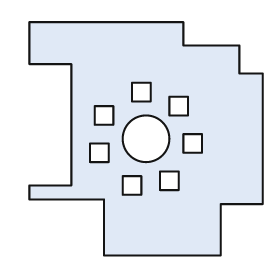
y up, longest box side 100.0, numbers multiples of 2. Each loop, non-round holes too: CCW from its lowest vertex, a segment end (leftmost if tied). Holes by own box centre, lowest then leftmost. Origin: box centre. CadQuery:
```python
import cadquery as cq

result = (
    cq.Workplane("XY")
    .moveTo(-18.0, -50.0)
    .lineTo(32.0, -50.0)
    .lineTo(32.0, -28.0)
    .lineTo(50.0, -28.0)
    .lineTo(50.0, 28.0)
    .lineTo(40.0, 28.0)
    .lineTo(40.0, 40.0)
    .lineTo(16.0, 40.0)
    .lineTo(16.0, 50.0)
    .lineTo(-50.0, 50.0)
    .lineTo(-50.0, 32.0)
    .lineTo(-32.0, 32.0)
    .lineTo(-32.0, -20.0)
    .lineTo(-50.0, -20.0)
    .lineTo(-50.0, -26.0)
    .lineTo(-18.0, -26.0)
    .close()
    .moveTo(-10.0, -24.0)
    .lineTo(-2.0, -24.0)
    .lineTo(-2.0, -16.0)
    .lineTo(-10.0, -16.0)
    .close()
    .moveTo(6.0, -22.0)
    .lineTo(14.0, -22.0)
    .lineTo(14.0, -14.0)
    .lineTo(6.0, -14.0)
    .close()
    .moveTo(-24.0, -10.0)
    .lineTo(-16.0, -10.0)
    .lineTo(-16.0, -2.0)
    .lineTo(-24.0, -2.0)
    .close()
    .moveTo(16.0, -6.0)
    .lineTo(24.0, -6.0)
    .lineTo(24.0, 2.0)
    .lineTo(16.0, 2.0)
    .close()
    .moveTo(0.0, 0.0)
    .circle(10.0)
    .moveTo(-22.0, 6.0)
    .lineTo(-14.0, 6.0)
    .lineTo(-14.0, 14.0)
    .lineTo(-22.0, 14.0)
    .close()
    .moveTo(10.0, 10.0)
    .lineTo(18.0, 10.0)
    .lineTo(18.0, 18.0)
    .lineTo(10.0, 18.0)
    .close()
    .moveTo(-6.0, 16.0)
    .lineTo(2.0, 16.0)
    .lineTo(2.0, 24.0)
    .lineTo(-6.0, 24.0)
    .close()
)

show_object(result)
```